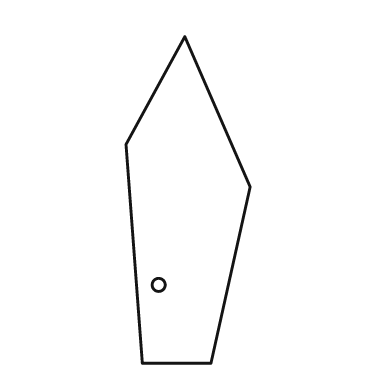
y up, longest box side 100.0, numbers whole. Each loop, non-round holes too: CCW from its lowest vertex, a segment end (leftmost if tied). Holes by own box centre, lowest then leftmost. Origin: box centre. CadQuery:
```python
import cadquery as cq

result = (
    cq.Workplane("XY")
    .moveTo(-14.0, -50.0)
    .lineTo(7.0, -50.0)
    .lineTo(19.0, 4.0)
    .lineTo(-1.0, 50.0)
    .lineTo(-19.0, 17.0)
    .close()
    .moveTo(-9.0, -26.0)
    .circle(2.0)
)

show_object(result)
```